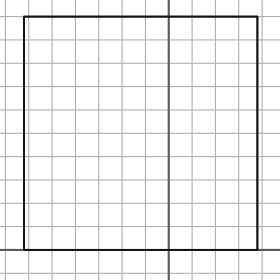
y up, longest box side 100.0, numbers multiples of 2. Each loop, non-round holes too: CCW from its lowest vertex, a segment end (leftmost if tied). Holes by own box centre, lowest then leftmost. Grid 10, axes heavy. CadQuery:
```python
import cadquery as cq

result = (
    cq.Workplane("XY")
    .moveTo(-62.0, 0.0)
    .lineTo(38.0, 0.0)
    .lineTo(38.0, 100.0)
    .lineTo(-62.0, 100.0)
    .close()
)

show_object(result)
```